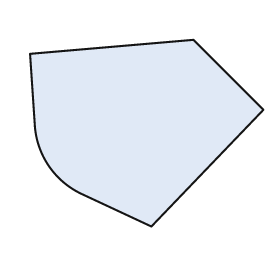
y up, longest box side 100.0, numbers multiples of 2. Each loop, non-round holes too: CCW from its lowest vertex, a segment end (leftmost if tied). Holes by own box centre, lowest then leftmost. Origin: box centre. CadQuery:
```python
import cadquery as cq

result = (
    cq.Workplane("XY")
    .moveTo(2.0, -40.0)
    .lineTo(50.0, 10.0)
    .lineTo(20.0, 40.0)
    .lineTo(-50.0, 34.0)
    .lineTo(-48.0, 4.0)
    .threePointArc((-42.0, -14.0), (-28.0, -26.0))
    .close()
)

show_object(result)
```